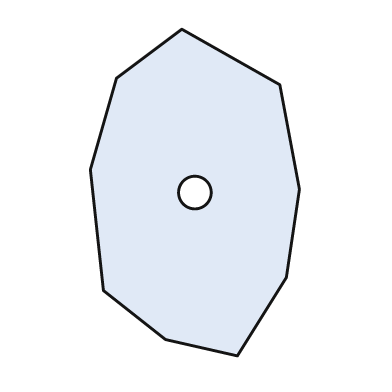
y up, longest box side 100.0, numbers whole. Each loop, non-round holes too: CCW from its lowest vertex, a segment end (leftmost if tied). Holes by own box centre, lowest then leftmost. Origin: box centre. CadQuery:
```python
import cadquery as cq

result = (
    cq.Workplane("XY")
    .moveTo(13.0, -50.0)
    .lineTo(28.0, -26.0)
    .lineTo(32.0, 1.0)
    .lineTo(26.0, 33.0)
    .lineTo(-4.0, 50.0)
    .lineTo(-24.0, 35.0)
    .lineTo(-32.0, 7.0)
    .lineTo(-28.0, -30.0)
    .lineTo(-9.0, -45.0)
    .close()
    .moveTo(0.0, 0.0)
    .circle(5.0)
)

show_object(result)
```